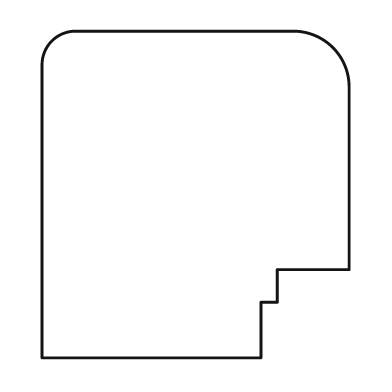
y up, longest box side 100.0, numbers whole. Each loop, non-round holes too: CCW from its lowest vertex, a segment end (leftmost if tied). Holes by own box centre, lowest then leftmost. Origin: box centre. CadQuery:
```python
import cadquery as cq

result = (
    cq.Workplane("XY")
    .moveTo(-47.0, -50.0)
    .lineTo(20.0, -50.0)
    .lineTo(20.0, -33.0)
    .lineTo(25.0, -33.0)
    .lineTo(25.0, -23.0)
    .lineTo(47.0, -23.0)
    .lineTo(47.0, 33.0)
    .threePointArc((42.0, 45.0), (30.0, 50.0))
    .lineTo(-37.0, 50.0)
    .threePointArc((-44.0, 47.0), (-47.0, 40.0))
    .close()
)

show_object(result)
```